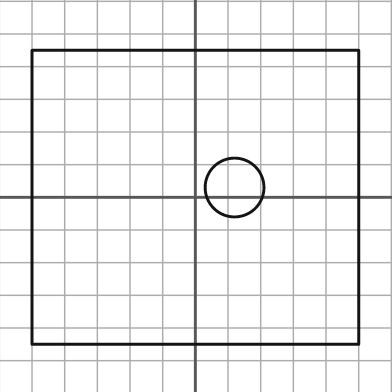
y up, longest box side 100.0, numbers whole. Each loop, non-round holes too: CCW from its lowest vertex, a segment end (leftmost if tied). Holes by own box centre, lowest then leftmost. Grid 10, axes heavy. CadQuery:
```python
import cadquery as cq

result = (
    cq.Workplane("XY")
    .moveTo(-50.0, -45.0)
    .lineTo(50.0, -45.0)
    .lineTo(50.0, 45.0)
    .lineTo(-50.0, 45.0)
    .close()
    .moveTo(12.0, 3.0)
    .circle(9.0)
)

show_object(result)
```